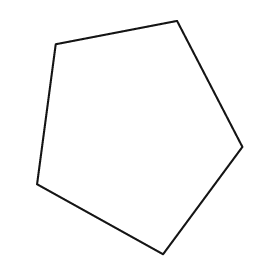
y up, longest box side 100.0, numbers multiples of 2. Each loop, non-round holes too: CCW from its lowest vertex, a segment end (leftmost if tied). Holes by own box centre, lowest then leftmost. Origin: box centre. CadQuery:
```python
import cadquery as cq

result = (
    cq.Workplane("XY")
    .moveTo(10.0, -50.0)
    .lineTo(44.0, -4.0)
    .lineTo(16.0, 50.0)
    .lineTo(-36.0, 40.0)
    .lineTo(-44.0, -20.0)
    .close()
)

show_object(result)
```